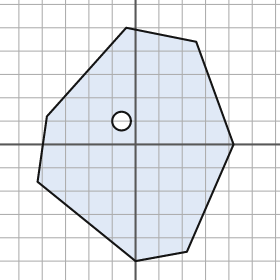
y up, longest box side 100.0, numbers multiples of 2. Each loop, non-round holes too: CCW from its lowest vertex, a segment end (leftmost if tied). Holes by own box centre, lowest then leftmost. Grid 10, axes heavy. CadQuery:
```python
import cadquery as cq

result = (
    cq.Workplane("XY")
    .moveTo(0.0, -50.0)
    .lineTo(22.0, -46.0)
    .lineTo(42.0, 0.0)
    .lineTo(26.0, 44.0)
    .lineTo(-4.0, 50.0)
    .lineTo(-38.0, 12.0)
    .lineTo(-42.0, -16.0)
    .close()
    .moveTo(-6.0, 10.0)
    .circle(4.0)
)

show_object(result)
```